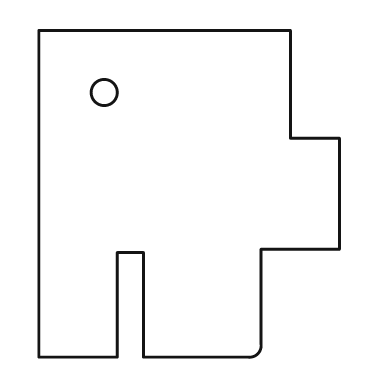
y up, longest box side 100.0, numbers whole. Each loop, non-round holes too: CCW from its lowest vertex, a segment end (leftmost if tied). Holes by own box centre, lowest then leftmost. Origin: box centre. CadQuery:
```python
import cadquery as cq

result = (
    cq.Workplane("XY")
    .moveTo(-46.0, -50.0)
    .lineTo(-22.0, -50.0)
    .lineTo(-22.0, -18.0)
    .lineTo(-14.0, -18.0)
    .lineTo(-14.0, -50.0)
    .lineTo(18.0, -50.0)
    .threePointArc((21.0, -49.0), (22.0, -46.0))
    .lineTo(22.0, -17.0)
    .lineTo(46.0, -17.0)
    .lineTo(46.0, 17.0)
    .lineTo(31.0, 17.0)
    .lineTo(31.0, 50.0)
    .lineTo(-46.0, 50.0)
    .close()
    .moveTo(-26.0, 31.0)
    .circle(4.0)
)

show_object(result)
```